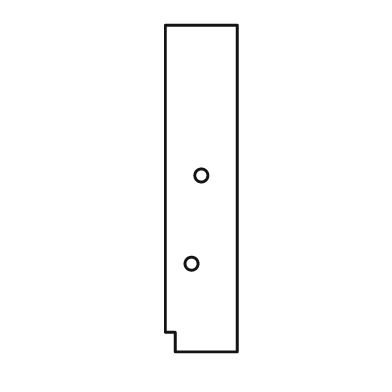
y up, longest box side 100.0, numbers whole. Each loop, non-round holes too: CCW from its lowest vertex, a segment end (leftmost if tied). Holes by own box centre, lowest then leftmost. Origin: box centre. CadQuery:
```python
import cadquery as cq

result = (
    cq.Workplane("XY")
    .moveTo(-8.0, -50.0)
    .lineTo(11.0, -50.0)
    .lineTo(11.0, 50.0)
    .lineTo(-11.0, 50.0)
    .lineTo(-11.0, -44.0)
    .lineTo(-8.0, -44.0)
    .close()
    .moveTo(-3.0, -23.0)
    .circle(2.0)
    .moveTo(0.0, 4.0)
    .circle(2.0)
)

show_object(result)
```